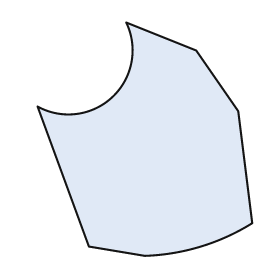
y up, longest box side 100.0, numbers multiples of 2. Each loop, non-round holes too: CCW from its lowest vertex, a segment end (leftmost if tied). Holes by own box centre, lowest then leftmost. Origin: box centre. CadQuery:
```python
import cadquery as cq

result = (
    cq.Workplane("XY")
    .moveTo(0.0, -50.0)
    .threePointArc((24.0, -46.0), (46.0, -36.0))
    .lineTo(40.0, 12.0)
    .lineTo(22.0, 38.0)
    .lineTo(-8.0, 50.0)
    .threePointArc((-14.0, 18.0), (-46.0, 14.0))
    .lineTo(-24.0, -46.0)
    .close()
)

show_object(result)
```